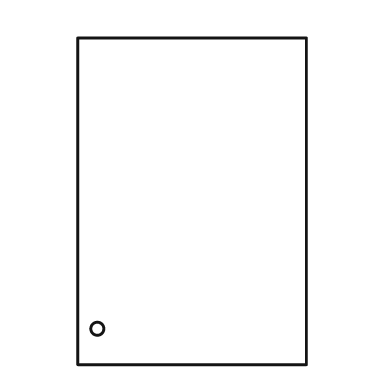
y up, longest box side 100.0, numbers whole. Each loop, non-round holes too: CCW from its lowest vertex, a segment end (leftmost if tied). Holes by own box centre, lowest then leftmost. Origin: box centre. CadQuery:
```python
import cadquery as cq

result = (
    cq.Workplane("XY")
    .moveTo(-35.0, -50.0)
    .lineTo(35.0, -50.0)
    .lineTo(35.0, 50.0)
    .lineTo(-35.0, 50.0)
    .close()
    .moveTo(-29.0, -39.0)
    .circle(2.0)
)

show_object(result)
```